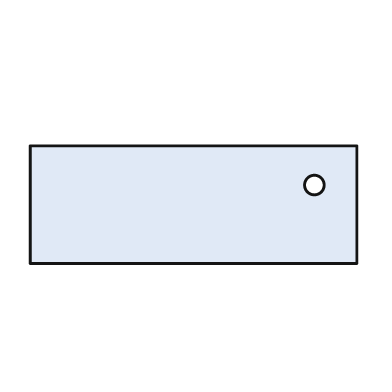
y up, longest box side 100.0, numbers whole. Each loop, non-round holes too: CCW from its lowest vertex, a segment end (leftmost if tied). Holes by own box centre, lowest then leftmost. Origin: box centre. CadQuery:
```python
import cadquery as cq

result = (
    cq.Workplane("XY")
    .moveTo(-50.0, -18.0)
    .lineTo(50.0, -18.0)
    .lineTo(50.0, 18.0)
    .lineTo(-50.0, 18.0)
    .close()
    .moveTo(37.0, 6.0)
    .circle(3.0)
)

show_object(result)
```